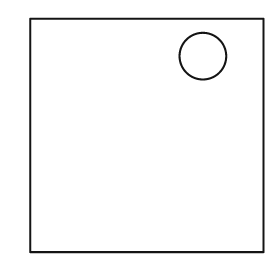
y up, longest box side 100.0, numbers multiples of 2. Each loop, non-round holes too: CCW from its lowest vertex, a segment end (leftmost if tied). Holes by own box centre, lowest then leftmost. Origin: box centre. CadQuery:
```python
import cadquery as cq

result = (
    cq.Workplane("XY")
    .moveTo(-50.0, -50.0)
    .lineTo(50.0, -50.0)
    .lineTo(50.0, 50.0)
    .lineTo(-50.0, 50.0)
    .close()
    .moveTo(24.0, 34.0)
    .circle(10.0)
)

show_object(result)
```